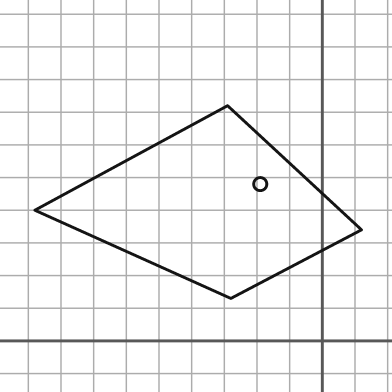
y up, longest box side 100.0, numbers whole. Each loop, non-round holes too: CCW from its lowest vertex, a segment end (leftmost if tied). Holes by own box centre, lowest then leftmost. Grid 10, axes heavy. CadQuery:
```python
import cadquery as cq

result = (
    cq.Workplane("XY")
    .moveTo(-28.0, 13.0)
    .lineTo(12.0, 34.0)
    .lineTo(-29.0, 72.0)
    .lineTo(-88.0, 40.0)
    .close()
    .moveTo(-19.0, 48.0)
    .circle(2.0)
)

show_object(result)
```